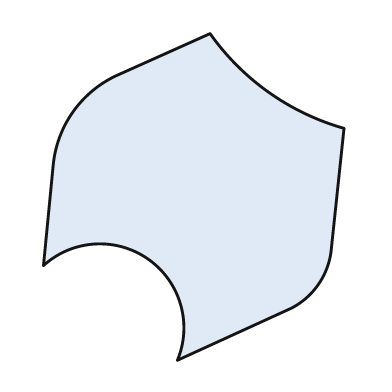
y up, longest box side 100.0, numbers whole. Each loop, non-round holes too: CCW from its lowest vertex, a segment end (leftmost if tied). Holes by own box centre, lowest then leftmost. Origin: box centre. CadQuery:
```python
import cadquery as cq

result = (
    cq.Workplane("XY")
    .moveTo(-5.0, -50.0)
    .lineTo(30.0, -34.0)
    .threePointArc((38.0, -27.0), (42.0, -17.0))
    .lineTo(46.0, 21.0)
    .threePointArc((23.0, 32.0), (5.0, 50.0))
    .lineTo(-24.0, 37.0)
    .threePointArc((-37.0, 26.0), (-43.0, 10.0))
    .lineTo(-46.0, -21.0)
    .threePointArc((-14.0, -19.0), (-5.0, -50.0))
    .close()
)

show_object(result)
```